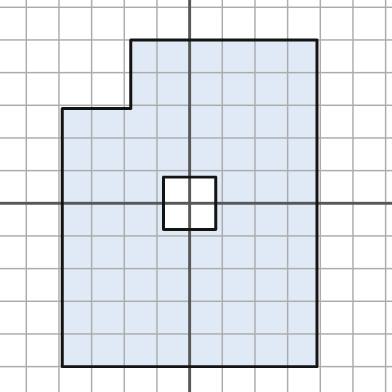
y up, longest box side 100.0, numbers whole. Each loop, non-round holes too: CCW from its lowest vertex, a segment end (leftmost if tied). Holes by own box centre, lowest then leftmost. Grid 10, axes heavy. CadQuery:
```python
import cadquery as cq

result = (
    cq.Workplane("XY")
    .moveTo(-39.0, -50.0)
    .lineTo(39.0, -50.0)
    .lineTo(39.0, 50.0)
    .lineTo(-18.0, 50.0)
    .lineTo(-18.0, 29.0)
    .lineTo(-39.0, 29.0)
    .close()
    .moveTo(-8.0, -8.0)
    .lineTo(8.0, -8.0)
    .lineTo(8.0, 8.0)
    .lineTo(-8.0, 8.0)
    .close()
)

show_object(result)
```